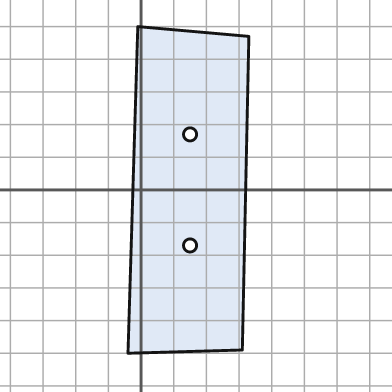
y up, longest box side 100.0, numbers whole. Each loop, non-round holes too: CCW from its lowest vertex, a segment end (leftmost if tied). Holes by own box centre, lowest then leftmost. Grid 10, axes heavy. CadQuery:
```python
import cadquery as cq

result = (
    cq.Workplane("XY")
    .moveTo(-4.0, -50.0)
    .lineTo(31.0, -49.0)
    .lineTo(33.0, 47.0)
    .lineTo(-1.0, 50.0)
    .close()
    .moveTo(15.0, -17.0)
    .circle(2.0)
    .moveTo(15.0, 17.0)
    .circle(2.0)
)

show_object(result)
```